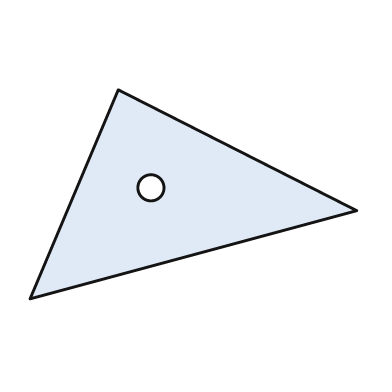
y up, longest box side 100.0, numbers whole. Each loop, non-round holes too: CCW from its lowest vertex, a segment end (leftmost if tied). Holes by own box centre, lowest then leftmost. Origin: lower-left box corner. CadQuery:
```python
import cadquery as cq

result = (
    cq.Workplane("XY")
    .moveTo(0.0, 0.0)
    .lineTo(100.0, 27.0)
    .lineTo(27.0, 64.0)
    .close()
    .moveTo(37.0, 34.0)
    .circle(4.0)
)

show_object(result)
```